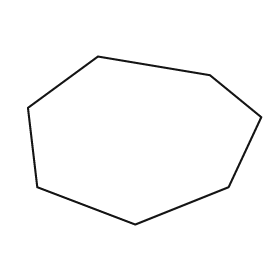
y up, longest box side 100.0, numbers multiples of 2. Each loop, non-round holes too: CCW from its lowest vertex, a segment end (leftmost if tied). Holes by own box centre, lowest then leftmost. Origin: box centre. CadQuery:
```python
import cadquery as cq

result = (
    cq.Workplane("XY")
    .moveTo(-4.0, -36.0)
    .lineTo(36.0, -20.0)
    .lineTo(50.0, 10.0)
    .lineTo(28.0, 28.0)
    .lineTo(-20.0, 36.0)
    .lineTo(-50.0, 14.0)
    .lineTo(-46.0, -20.0)
    .close()
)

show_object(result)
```